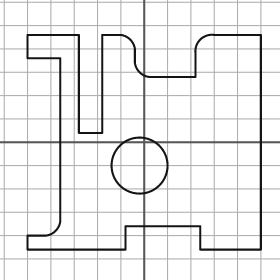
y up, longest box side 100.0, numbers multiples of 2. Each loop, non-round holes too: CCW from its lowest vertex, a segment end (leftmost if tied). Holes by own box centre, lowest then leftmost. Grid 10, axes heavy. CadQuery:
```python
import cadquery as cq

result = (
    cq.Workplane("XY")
    .moveTo(-50.0, -46.0)
    .lineTo(-8.0, -46.0)
    .lineTo(-8.0, -36.0)
    .lineTo(24.0, -36.0)
    .lineTo(24.0, -46.0)
    .lineTo(50.0, -46.0)
    .lineTo(50.0, 46.0)
    .lineTo(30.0, 46.0)
    .threePointArc((24.0, 44.0), (22.0, 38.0))
    .lineTo(22.0, 28.0)
    .lineTo(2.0, 28.0)
    .threePointArc((-2.0, 30.0), (-4.0, 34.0))
    .lineTo(-4.0, 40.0)
    .threePointArc((-6.0, 44.0), (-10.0, 46.0))
    .lineTo(-18.0, 46.0)
    .lineTo(-18.0, 4.0)
    .lineTo(-28.0, 4.0)
    .lineTo(-28.0, 46.0)
    .lineTo(-50.0, 46.0)
    .lineTo(-50.0, 36.0)
    .lineTo(-36.0, 36.0)
    .lineTo(-36.0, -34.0)
    .threePointArc((-38.0, -38.0), (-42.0, -40.0))
    .lineTo(-50.0, -40.0)
    .close()
    .moveTo(-2.0, -10.0)
    .circle(12.0)
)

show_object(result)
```